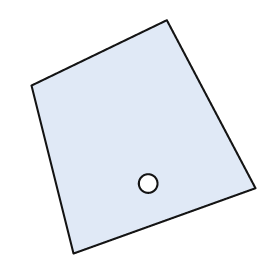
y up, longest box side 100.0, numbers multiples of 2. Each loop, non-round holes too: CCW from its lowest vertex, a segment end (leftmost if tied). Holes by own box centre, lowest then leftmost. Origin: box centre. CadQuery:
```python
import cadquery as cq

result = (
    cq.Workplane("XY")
    .moveTo(-30.0, -50.0)
    .lineTo(48.0, -22.0)
    .lineTo(10.0, 50.0)
    .lineTo(-48.0, 22.0)
    .close()
    .moveTo(2.0, -20.0)
    .circle(4.0)
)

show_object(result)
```